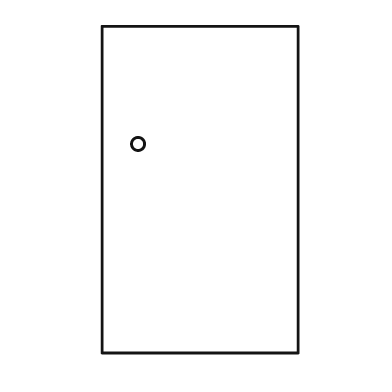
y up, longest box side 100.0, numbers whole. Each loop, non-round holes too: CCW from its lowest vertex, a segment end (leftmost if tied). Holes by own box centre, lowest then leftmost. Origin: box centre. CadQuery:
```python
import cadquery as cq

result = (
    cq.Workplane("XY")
    .moveTo(-30.0, -50.0)
    .lineTo(30.0, -50.0)
    .lineTo(30.0, 50.0)
    .lineTo(-30.0, 50.0)
    .close()
    .moveTo(-19.0, 14.0)
    .circle(2.0)
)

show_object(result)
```